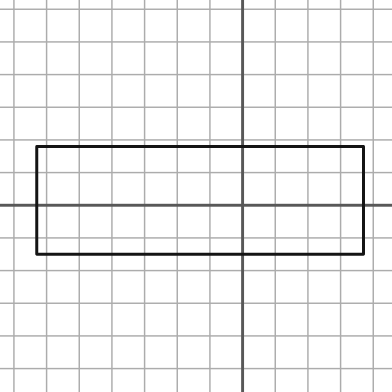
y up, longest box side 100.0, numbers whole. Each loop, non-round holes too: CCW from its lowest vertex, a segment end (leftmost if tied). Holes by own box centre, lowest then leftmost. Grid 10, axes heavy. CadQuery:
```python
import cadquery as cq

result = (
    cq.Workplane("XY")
    .moveTo(-63.0, -15.0)
    .lineTo(37.0, -15.0)
    .lineTo(37.0, 18.0)
    .lineTo(-63.0, 18.0)
    .close()
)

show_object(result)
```